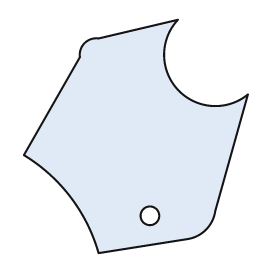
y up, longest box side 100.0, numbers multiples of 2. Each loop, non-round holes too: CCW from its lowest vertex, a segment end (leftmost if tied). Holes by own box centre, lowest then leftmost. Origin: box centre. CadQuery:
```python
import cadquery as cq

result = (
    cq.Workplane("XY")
    .moveTo(-16.0, -50.0)
    .lineTo(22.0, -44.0)
    .threePointArc((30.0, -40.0), (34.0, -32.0))
    .lineTo(48.0, 18.0)
    .threePointArc((18.0, 20.0), (18.0, 50.0))
    .lineTo(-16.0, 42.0)
    .threePointArc((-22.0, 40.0), (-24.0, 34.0))
    .lineTo(-48.0, -8.0)
    .threePointArc((-28.0, -26.0), (-16.0, -50.0))
    .close()
    .moveTo(6.0, -34.0)
    .circle(4.0)
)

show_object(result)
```